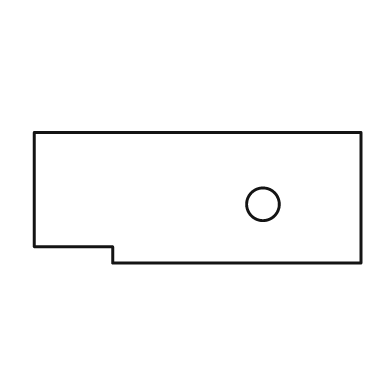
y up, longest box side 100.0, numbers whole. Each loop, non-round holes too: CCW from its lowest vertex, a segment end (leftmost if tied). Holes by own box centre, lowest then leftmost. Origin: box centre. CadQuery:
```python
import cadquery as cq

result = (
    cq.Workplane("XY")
    .moveTo(-26.0, -20.0)
    .lineTo(50.0, -20.0)
    .lineTo(50.0, 20.0)
    .lineTo(-50.0, 20.0)
    .lineTo(-50.0, -15.0)
    .lineTo(-26.0, -15.0)
    .close()
    .moveTo(20.0, -2.0)
    .circle(5.0)
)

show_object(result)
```